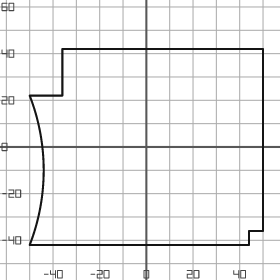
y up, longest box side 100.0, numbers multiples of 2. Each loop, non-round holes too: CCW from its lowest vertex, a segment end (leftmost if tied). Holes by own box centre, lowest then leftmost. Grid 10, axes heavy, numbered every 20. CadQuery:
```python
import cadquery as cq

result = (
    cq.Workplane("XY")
    .moveTo(-50.0, -42.0)
    .lineTo(44.0, -42.0)
    .lineTo(44.0, -36.0)
    .lineTo(50.0, -36.0)
    .lineTo(50.0, 42.0)
    .lineTo(-36.0, 42.0)
    .lineTo(-36.0, 22.0)
    .lineTo(-50.0, 22.0)
    .threePointArc((-44.0, -10.0), (-50.0, -42.0))
    .close()
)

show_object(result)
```